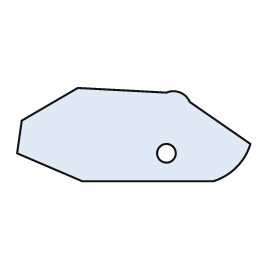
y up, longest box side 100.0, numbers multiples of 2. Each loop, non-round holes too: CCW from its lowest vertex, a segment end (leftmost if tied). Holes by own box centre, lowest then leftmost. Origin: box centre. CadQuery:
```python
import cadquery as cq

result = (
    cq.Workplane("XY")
    .moveTo(-22.0, -20.0)
    .lineTo(34.0, -20.0)
    .threePointArc((44.0, -14.0), (50.0, -4.0))
    .lineTo(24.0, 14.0)
    .threePointArc((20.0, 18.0), (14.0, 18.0))
    .lineTo(-24.0, 20.0)
    .lineTo(-48.0, 6.0)
    .lineTo(-50.0, -8.0)
    .close()
    .moveTo(14.0, -8.0)
    .circle(4.0)
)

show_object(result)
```